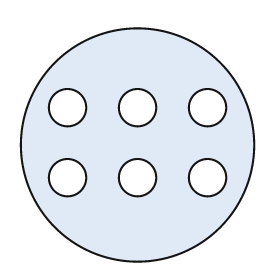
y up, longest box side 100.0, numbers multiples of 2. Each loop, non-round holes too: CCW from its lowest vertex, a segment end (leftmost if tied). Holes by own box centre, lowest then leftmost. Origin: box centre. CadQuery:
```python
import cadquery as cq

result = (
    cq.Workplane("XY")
    .moveTo(0.0, 0.0)
    .circle(50.0)
    .moveTo(-30.0, -14.0)
    .circle(8.0)
    .moveTo(0.0, -14.0)
    .circle(8.0)
    .moveTo(30.0, -14.0)
    .circle(8.0)
    .moveTo(-30.0, 16.0)
    .circle(8.0)
    .moveTo(0.0, 16.0)
    .circle(8.0)
    .moveTo(30.0, 16.0)
    .circle(8.0)
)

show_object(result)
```